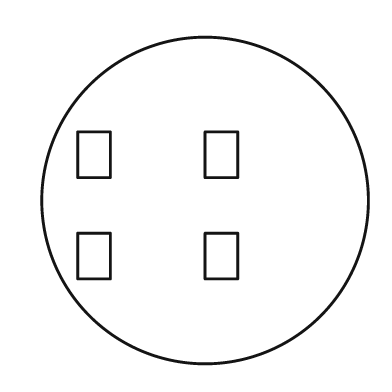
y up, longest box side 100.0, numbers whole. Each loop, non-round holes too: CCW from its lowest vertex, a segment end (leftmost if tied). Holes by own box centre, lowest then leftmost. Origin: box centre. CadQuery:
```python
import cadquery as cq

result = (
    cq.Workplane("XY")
    .moveTo(0.0, 0.0)
    .circle(50.0)
    .moveTo(-39.0, -24.0)
    .lineTo(-29.0, -24.0)
    .lineTo(-29.0, -10.0)
    .lineTo(-39.0, -10.0)
    .close()
    .moveTo(0.0, -24.0)
    .lineTo(10.0, -24.0)
    .lineTo(10.0, -10.0)
    .lineTo(0.0, -10.0)
    .close()
    .moveTo(-39.0, 7.0)
    .lineTo(-29.0, 7.0)
    .lineTo(-29.0, 21.0)
    .lineTo(-39.0, 21.0)
    .close()
    .moveTo(0.0, 7.0)
    .lineTo(10.0, 7.0)
    .lineTo(10.0, 21.0)
    .lineTo(0.0, 21.0)
    .close()
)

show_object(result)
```